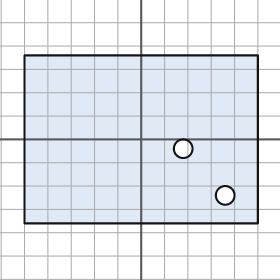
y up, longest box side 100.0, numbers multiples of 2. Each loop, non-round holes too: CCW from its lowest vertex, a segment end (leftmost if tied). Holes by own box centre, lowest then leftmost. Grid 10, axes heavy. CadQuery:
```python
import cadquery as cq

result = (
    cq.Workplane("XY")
    .moveTo(-50.0, -36.0)
    .lineTo(50.0, -36.0)
    .lineTo(50.0, 36.0)
    .lineTo(-50.0, 36.0)
    .close()
    .moveTo(36.0, -24.0)
    .circle(4.0)
    .moveTo(18.0, -4.0)
    .circle(4.0)
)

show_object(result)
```